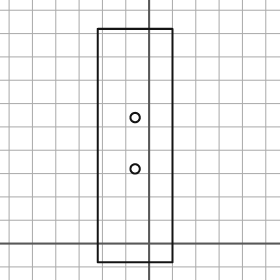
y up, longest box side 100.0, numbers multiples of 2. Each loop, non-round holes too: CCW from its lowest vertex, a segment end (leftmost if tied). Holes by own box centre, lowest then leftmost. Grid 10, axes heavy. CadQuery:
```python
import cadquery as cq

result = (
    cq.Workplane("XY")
    .moveTo(-22.0, -8.0)
    .lineTo(10.0, -8.0)
    .lineTo(10.0, 92.0)
    .lineTo(-22.0, 92.0)
    .close()
    .moveTo(-6.0, 32.0)
    .circle(2.0)
    .moveTo(-6.0, 54.0)
    .circle(2.0)
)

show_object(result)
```